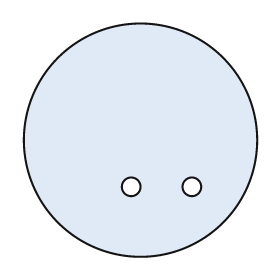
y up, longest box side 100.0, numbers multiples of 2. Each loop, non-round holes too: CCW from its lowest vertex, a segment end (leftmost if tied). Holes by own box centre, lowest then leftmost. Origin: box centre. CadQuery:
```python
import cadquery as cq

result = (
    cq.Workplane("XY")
    .moveTo(0.0, 0.0)
    .circle(50.0)
    .moveTo(-4.0, -20.0)
    .circle(4.0)
    .moveTo(22.0, -20.0)
    .circle(4.0)
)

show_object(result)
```